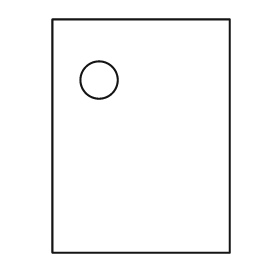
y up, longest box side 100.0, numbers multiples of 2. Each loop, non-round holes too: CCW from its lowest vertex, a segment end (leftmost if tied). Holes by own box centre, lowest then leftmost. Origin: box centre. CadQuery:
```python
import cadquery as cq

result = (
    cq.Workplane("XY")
    .moveTo(-38.0, -50.0)
    .lineTo(38.0, -50.0)
    .lineTo(38.0, 50.0)
    .lineTo(-38.0, 50.0)
    .close()
    .moveTo(-18.0, 24.0)
    .circle(8.0)
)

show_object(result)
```